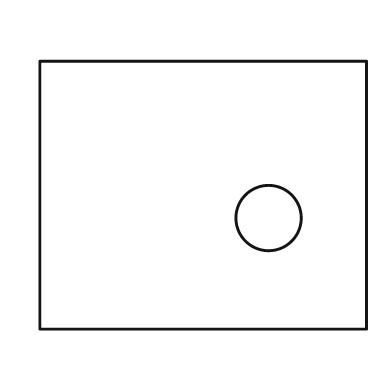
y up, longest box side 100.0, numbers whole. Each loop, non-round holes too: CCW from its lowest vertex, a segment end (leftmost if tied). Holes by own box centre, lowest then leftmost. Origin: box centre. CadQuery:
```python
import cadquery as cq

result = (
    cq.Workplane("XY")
    .moveTo(-50.0, -41.0)
    .lineTo(50.0, -41.0)
    .lineTo(50.0, 41.0)
    .lineTo(-50.0, 41.0)
    .close()
    .moveTo(20.0, -7.0)
    .circle(10.0)
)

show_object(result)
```